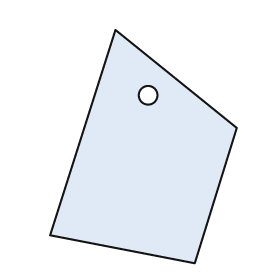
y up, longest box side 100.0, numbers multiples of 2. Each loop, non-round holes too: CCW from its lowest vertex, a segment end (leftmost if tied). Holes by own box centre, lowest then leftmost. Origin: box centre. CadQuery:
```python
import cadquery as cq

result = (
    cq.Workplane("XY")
    .moveTo(22.0, -50.0)
    .lineTo(40.0, 8.0)
    .lineTo(-12.0, 50.0)
    .lineTo(-40.0, -38.0)
    .close()
    .moveTo(2.0, 22.0)
    .circle(4.0)
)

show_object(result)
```